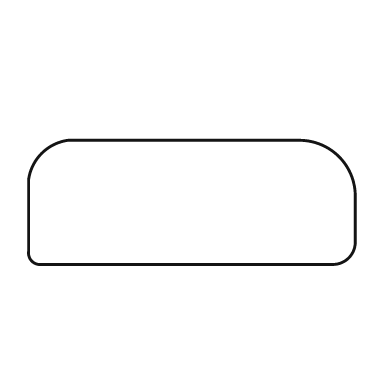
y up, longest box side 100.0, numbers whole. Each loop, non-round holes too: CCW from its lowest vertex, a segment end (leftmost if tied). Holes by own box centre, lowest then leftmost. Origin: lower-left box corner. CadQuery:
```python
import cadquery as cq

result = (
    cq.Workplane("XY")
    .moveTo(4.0, 0.0)
    .lineTo(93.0, 0.0)
    .threePointArc((98.0, 2.0), (100.0, 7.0))
    .lineTo(100.0, 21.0)
    .threePointArc((95.0, 33.0), (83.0, 38.0))
    .lineTo(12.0, 38.0)
    .threePointArc((4.0, 34.0), (0.0, 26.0))
    .lineTo(0.0, 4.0)
    .threePointArc((1.0, 1.0), (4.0, 0.0))
    .close()
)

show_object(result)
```